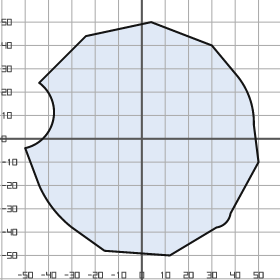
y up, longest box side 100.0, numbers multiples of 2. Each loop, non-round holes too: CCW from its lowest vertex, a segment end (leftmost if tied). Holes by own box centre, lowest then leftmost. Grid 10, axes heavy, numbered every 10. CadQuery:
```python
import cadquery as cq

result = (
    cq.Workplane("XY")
    .moveTo(12.0, -50.0)
    .lineTo(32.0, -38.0)
    .threePointArc((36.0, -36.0), (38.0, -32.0))
    .lineTo(50.0, -10.0)
    .lineTo(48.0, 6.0)
    .threePointArc((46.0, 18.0), (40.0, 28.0))
    .lineTo(30.0, 40.0)
    .lineTo(4.0, 50.0)
    .lineTo(-24.0, 44.0)
    .lineTo(-44.0, 24.0)
    .threePointArc((-38.0, 8.0), (-50.0, -4.0))
    .lineTo(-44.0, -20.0)
    .threePointArc((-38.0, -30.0), (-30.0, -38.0))
    .lineTo(-16.0, -48.0)
    .close()
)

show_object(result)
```